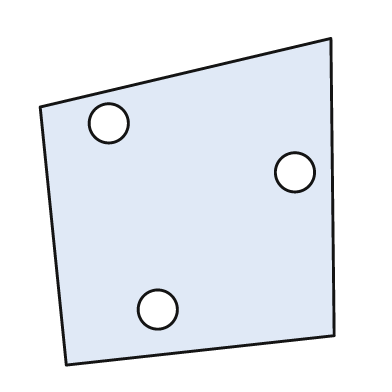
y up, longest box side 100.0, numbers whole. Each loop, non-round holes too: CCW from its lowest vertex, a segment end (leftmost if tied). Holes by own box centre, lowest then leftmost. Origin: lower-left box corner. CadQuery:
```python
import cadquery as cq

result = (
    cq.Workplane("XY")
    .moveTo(8.0, 0.0)
    .lineTo(90.0, 9.0)
    .lineTo(89.0, 100.0)
    .lineTo(0.0, 79.0)
    .close()
    .moveTo(36.0, 17.0)
    .circle(6.0)
    .moveTo(78.0, 59.0)
    .circle(6.0)
    .moveTo(21.0, 74.0)
    .circle(6.0)
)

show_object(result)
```